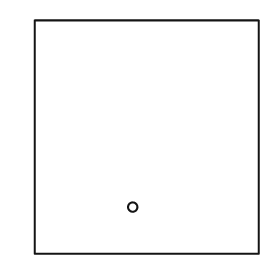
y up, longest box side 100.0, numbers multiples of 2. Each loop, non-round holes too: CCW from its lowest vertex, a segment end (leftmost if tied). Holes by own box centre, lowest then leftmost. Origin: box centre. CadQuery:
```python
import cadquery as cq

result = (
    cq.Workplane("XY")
    .moveTo(-48.0, -50.0)
    .lineTo(48.0, -50.0)
    .lineTo(48.0, 50.0)
    .lineTo(-48.0, 50.0)
    .close()
    .moveTo(-6.0, -30.0)
    .circle(2.0)
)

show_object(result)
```